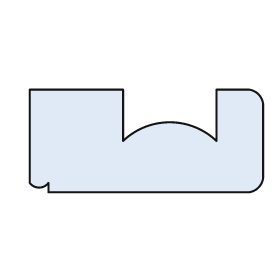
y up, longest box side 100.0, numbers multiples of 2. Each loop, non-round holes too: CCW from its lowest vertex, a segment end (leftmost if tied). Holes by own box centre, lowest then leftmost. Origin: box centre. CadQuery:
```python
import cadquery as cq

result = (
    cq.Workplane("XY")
    .moveTo(-42.0, -22.0)
    .lineTo(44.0, -22.0)
    .threePointArc((48.0, -20.0), (50.0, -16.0))
    .lineTo(50.0, 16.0)
    .threePointArc((48.0, 20.0), (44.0, 22.0))
    .lineTo(30.0, 22.0)
    .lineTo(30.0, 0.0)
    .threePointArc((10.0, 8.0), (-10.0, 0.0))
    .lineTo(-10.0, 22.0)
    .lineTo(-50.0, 22.0)
    .lineTo(-50.0, -18.0)
    .threePointArc((-46.0, -20.0), (-42.0, -18.0))
    .close()
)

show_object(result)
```